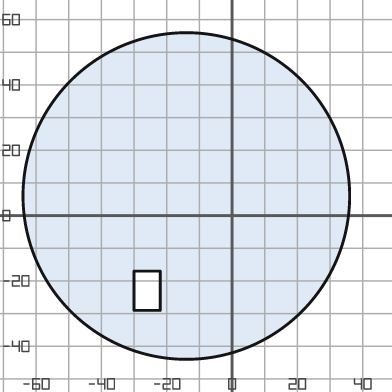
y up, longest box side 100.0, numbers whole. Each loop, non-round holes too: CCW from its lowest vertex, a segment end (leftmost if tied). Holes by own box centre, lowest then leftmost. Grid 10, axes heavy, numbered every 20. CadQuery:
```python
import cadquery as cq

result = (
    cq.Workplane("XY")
    .moveTo(-14.0, 6.0)
    .circle(50.0)
    .moveTo(-30.0, -29.0)
    .lineTo(-22.0, -29.0)
    .lineTo(-22.0, -17.0)
    .lineTo(-30.0, -17.0)
    .close()
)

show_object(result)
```